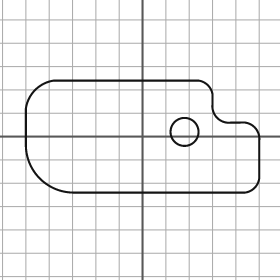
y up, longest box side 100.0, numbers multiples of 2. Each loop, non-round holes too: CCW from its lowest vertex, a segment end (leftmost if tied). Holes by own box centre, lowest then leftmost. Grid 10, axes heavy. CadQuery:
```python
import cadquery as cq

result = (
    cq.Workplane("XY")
    .moveTo(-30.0, -24.0)
    .lineTo(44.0, -24.0)
    .threePointArc((48.0, -22.0), (50.0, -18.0))
    .lineTo(50.0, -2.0)
    .threePointArc((48.0, 4.0), (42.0, 6.0))
    .lineTo(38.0, 6.0)
    .threePointArc((32.0, 8.0), (30.0, 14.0))
    .lineTo(30.0, 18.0)
    .threePointArc((28.0, 22.0), (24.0, 24.0))
    .lineTo(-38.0, 24.0)
    .threePointArc((-46.0, 20.0), (-50.0, 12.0))
    .lineTo(-50.0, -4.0)
    .threePointArc((-44.0, -18.0), (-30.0, -24.0))
    .close()
    .moveTo(18.0, 2.0)
    .circle(6.0)
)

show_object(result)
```